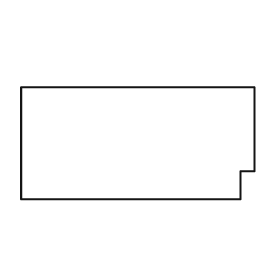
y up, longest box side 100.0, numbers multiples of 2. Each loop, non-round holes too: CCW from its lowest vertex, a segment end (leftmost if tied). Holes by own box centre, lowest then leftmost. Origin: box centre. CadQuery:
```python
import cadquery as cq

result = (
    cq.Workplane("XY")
    .moveTo(-50.0, -24.0)
    .lineTo(44.0, -24.0)
    .lineTo(44.0, -12.0)
    .lineTo(50.0, -12.0)
    .lineTo(50.0, 24.0)
    .lineTo(-50.0, 24.0)
    .close()
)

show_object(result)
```